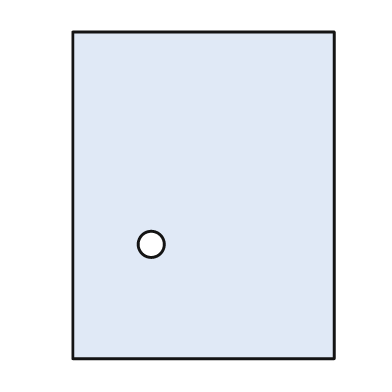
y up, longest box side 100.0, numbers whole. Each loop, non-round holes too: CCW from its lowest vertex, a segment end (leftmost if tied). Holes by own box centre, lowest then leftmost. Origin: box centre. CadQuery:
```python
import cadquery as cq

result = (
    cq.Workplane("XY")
    .moveTo(-40.0, -50.0)
    .lineTo(40.0, -50.0)
    .lineTo(40.0, 50.0)
    .lineTo(-40.0, 50.0)
    .close()
    .moveTo(-16.0, -15.0)
    .circle(4.0)
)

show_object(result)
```